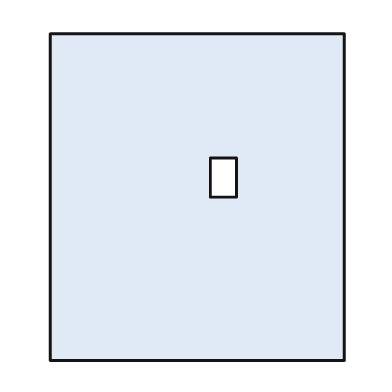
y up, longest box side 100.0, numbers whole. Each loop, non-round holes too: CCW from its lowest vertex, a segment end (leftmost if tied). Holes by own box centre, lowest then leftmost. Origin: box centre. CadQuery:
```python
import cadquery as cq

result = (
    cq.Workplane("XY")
    .moveTo(-45.0, -50.0)
    .lineTo(45.0, -50.0)
    .lineTo(45.0, 50.0)
    .lineTo(-45.0, 50.0)
    .close()
    .moveTo(4.0, 0.0)
    .lineTo(12.0, 0.0)
    .lineTo(12.0, 12.0)
    .lineTo(4.0, 12.0)
    .close()
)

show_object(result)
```